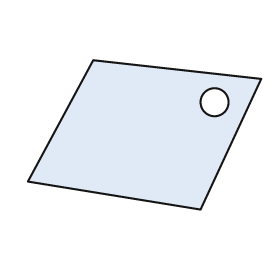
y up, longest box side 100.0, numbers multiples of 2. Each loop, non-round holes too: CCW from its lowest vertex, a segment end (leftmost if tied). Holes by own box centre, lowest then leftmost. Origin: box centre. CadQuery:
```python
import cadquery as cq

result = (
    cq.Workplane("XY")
    .moveTo(24.0, -32.0)
    .lineTo(50.0, 24.0)
    .lineTo(-22.0, 32.0)
    .lineTo(-50.0, -20.0)
    .close()
    .moveTo(30.0, 14.0)
    .circle(6.0)
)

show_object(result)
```